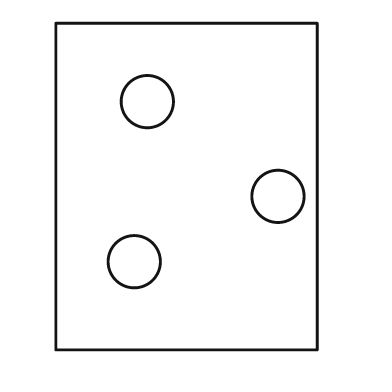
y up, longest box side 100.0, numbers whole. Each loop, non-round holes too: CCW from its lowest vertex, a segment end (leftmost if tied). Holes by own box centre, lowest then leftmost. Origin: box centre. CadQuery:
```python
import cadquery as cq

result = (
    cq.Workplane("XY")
    .moveTo(-40.0, -50.0)
    .lineTo(40.0, -50.0)
    .lineTo(40.0, 50.0)
    .lineTo(-40.0, 50.0)
    .close()
    .moveTo(-16.0, -23.0)
    .circle(8.0)
    .moveTo(28.0, -3.0)
    .circle(8.0)
    .moveTo(-12.0, 26.0)
    .circle(8.0)
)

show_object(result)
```